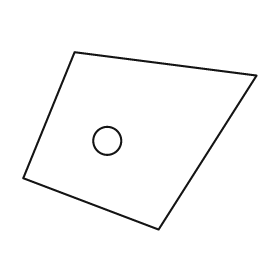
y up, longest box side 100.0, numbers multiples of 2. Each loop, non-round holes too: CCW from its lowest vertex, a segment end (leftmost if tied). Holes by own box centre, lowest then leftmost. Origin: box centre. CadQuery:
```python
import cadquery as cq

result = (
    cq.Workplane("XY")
    .moveTo(8.0, -38.0)
    .lineTo(50.0, 28.0)
    .lineTo(-28.0, 38.0)
    .lineTo(-50.0, -16.0)
    .close()
    .moveTo(-14.0, 0.0)
    .circle(6.0)
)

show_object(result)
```